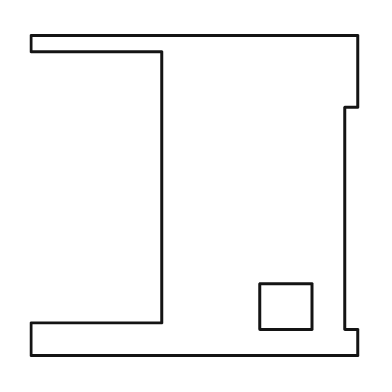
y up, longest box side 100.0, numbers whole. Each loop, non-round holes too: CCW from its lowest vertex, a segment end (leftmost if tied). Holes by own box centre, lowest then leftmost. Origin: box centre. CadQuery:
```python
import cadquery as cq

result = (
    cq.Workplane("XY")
    .moveTo(-50.0, -49.0)
    .lineTo(50.0, -49.0)
    .lineTo(50.0, -41.0)
    .lineTo(46.0, -41.0)
    .lineTo(46.0, 27.0)
    .lineTo(50.0, 27.0)
    .lineTo(50.0, 49.0)
    .lineTo(-50.0, 49.0)
    .lineTo(-50.0, 44.0)
    .lineTo(-10.0, 44.0)
    .lineTo(-10.0, -39.0)
    .lineTo(-50.0, -39.0)
    .close()
    .moveTo(20.0, -41.0)
    .lineTo(36.0, -41.0)
    .lineTo(36.0, -27.0)
    .lineTo(20.0, -27.0)
    .close()
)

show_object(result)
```